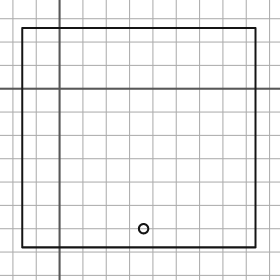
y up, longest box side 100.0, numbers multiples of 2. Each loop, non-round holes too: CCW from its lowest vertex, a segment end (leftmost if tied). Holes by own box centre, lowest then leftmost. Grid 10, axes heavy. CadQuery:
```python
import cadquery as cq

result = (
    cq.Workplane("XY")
    .moveTo(-16.0, -68.0)
    .lineTo(84.0, -68.0)
    .lineTo(84.0, 26.0)
    .lineTo(-16.0, 26.0)
    .close()
    .moveTo(36.0, -60.0)
    .circle(2.0)
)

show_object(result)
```